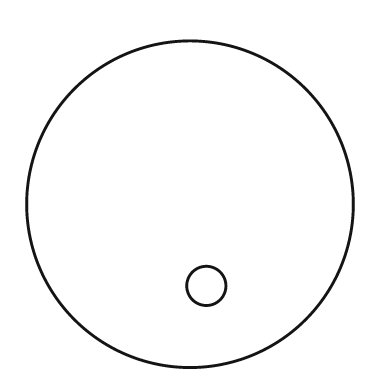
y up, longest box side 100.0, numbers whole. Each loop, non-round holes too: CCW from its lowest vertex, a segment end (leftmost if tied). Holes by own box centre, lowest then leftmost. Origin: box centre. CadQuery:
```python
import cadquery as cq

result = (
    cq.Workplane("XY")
    .moveTo(0.0, 0.0)
    .circle(50.0)
    .moveTo(5.0, -25.0)
    .circle(6.0)
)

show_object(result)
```